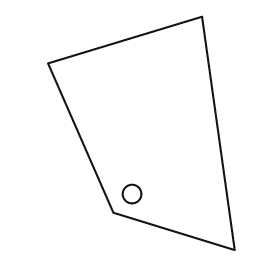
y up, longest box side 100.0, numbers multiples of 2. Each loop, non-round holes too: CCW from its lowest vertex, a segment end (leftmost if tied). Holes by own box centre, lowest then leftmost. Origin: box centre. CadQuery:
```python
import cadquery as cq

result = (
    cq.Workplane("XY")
    .moveTo(40.0, -50.0)
    .lineTo(26.0, 50.0)
    .lineTo(-40.0, 30.0)
    .lineTo(-12.0, -34.0)
    .close()
    .moveTo(-4.0, -26.0)
    .circle(4.0)
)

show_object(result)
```